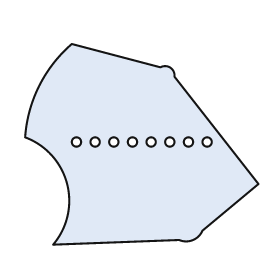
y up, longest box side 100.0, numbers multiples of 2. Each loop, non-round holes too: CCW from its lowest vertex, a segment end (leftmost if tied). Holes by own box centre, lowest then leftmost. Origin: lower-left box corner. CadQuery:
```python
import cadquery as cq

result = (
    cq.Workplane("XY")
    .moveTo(12.0, 0.0)
    .lineTo(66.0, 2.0)
    .threePointArc((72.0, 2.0), (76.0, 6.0))
    .lineTo(100.0, 26.0)
    .lineTo(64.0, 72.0)
    .threePointArc((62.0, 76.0), (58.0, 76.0))
    .lineTo(20.0, 86.0)
    .threePointArc((6.0, 68.0), (0.0, 46.0))
    .threePointArc((18.0, 26.0), (12.0, 0.0))
    .close()
    .moveTo(22.0, 44.0)
    .circle(2.0)
    .moveTo(30.0, 44.0)
    .circle(2.0)
    .moveTo(38.0, 44.0)
    .circle(2.0)
    .moveTo(46.0, 44.0)
    .circle(2.0)
    .moveTo(54.0, 44.0)
    .circle(2.0)
    .moveTo(62.0, 44.0)
    .circle(2.0)
    .moveTo(70.0, 44.0)
    .circle(2.0)
    .moveTo(78.0, 44.0)
    .circle(2.0)
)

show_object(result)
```